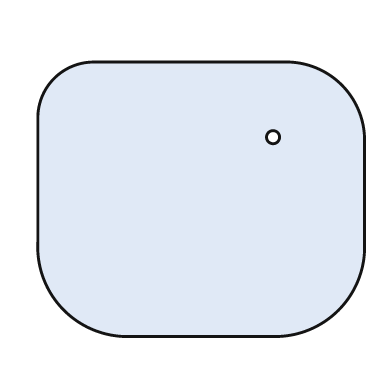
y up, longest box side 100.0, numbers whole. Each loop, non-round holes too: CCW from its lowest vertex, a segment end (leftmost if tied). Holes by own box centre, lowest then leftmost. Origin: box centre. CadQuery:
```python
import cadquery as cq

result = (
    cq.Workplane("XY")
    .moveTo(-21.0, -42.0)
    .lineTo(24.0, -42.0)
    .threePointArc((42.0, -34.0), (50.0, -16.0))
    .lineTo(50.0, 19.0)
    .threePointArc((43.0, 35.0), (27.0, 42.0))
    .lineTo(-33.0, 42.0)
    .threePointArc((-45.0, 37.0), (-50.0, 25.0))
    .lineTo(-50.0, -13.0)
    .threePointArc((-42.0, -34.0), (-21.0, -42.0))
    .close()
    .moveTo(22.0, 19.0)
    .circle(2.0)
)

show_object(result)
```